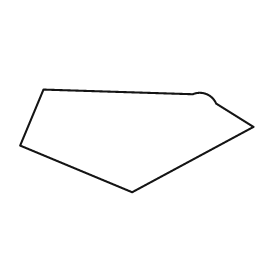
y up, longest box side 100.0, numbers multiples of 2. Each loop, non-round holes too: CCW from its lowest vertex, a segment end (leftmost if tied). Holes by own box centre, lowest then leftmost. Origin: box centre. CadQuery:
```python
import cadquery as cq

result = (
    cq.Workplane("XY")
    .moveTo(-2.0, -22.0)
    .lineTo(50.0, 6.0)
    .lineTo(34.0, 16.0)
    .threePointArc((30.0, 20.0), (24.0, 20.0))
    .lineTo(-40.0, 22.0)
    .lineTo(-50.0, -2.0)
    .close()
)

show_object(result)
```